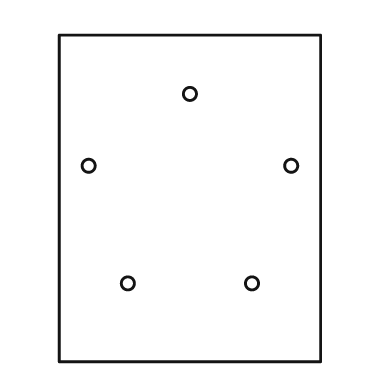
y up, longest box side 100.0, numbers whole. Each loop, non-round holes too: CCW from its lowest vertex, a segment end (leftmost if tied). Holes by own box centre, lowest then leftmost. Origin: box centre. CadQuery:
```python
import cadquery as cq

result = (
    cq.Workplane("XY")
    .moveTo(-40.0, -50.0)
    .lineTo(40.0, -50.0)
    .lineTo(40.0, 50.0)
    .lineTo(-40.0, 50.0)
    .close()
    .moveTo(-19.0, -26.0)
    .circle(2.0)
    .moveTo(19.0, -26.0)
    .circle(2.0)
    .moveTo(-31.0, 10.0)
    .circle(2.0)
    .moveTo(31.0, 10.0)
    .circle(2.0)
    .moveTo(0.0, 32.0)
    .circle(2.0)
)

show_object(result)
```